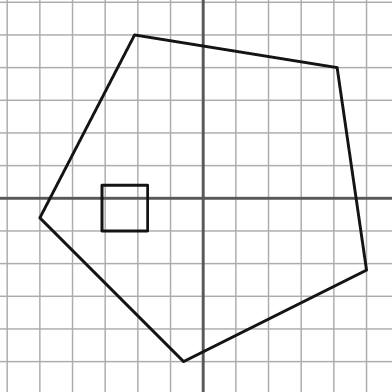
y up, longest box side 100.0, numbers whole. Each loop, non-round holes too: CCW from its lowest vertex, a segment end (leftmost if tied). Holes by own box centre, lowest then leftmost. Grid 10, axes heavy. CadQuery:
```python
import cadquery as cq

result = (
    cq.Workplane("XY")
    .moveTo(-6.0, -50.0)
    .lineTo(50.0, -22.0)
    .lineTo(41.0, 40.0)
    .lineTo(-21.0, 50.0)
    .lineTo(-50.0, -6.0)
    .close()
    .moveTo(-31.0, -10.0)
    .lineTo(-17.0, -10.0)
    .lineTo(-17.0, 4.0)
    .lineTo(-31.0, 4.0)
    .close()
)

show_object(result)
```